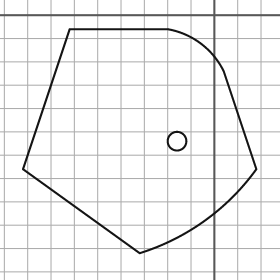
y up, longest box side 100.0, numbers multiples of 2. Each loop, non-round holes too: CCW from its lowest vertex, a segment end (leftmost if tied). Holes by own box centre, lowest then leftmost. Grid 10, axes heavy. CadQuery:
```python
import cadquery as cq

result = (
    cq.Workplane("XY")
    .moveTo(-32.0, -102.0)
    .threePointArc((-4.0, -88.0), (18.0, -66.0))
    .lineTo(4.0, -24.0)
    .threePointArc((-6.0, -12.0), (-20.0, -6.0))
    .lineTo(-62.0, -6.0)
    .lineTo(-82.0, -66.0)
    .close()
    .moveTo(-16.0, -54.0)
    .circle(4.0)
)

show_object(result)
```